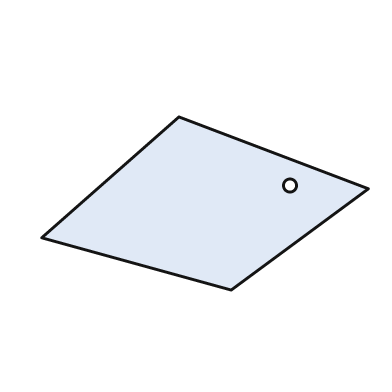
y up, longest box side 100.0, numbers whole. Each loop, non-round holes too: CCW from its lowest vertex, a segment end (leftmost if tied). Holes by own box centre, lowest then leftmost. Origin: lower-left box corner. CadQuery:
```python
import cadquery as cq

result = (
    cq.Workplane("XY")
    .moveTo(58.0, 0.0)
    .lineTo(100.0, 31.0)
    .lineTo(42.0, 53.0)
    .lineTo(0.0, 16.0)
    .close()
    .moveTo(76.0, 32.0)
    .circle(2.0)
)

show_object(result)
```